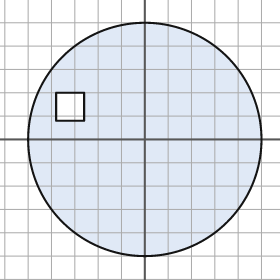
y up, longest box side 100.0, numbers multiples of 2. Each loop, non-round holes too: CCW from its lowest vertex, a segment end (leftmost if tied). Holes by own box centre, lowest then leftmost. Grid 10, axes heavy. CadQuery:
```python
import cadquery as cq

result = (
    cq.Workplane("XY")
    .moveTo(0.0, 0.0)
    .circle(50.0)
    .moveTo(-38.0, 8.0)
    .lineTo(-26.0, 8.0)
    .lineTo(-26.0, 20.0)
    .lineTo(-38.0, 20.0)
    .close()
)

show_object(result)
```